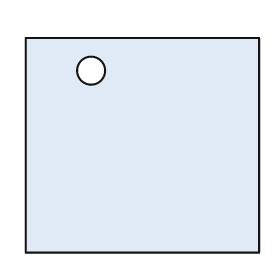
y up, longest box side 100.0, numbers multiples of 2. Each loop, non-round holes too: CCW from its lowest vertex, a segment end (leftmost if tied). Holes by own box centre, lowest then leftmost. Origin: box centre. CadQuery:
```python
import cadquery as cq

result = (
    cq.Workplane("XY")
    .moveTo(-50.0, -46.0)
    .lineTo(50.0, -46.0)
    .lineTo(50.0, 46.0)
    .lineTo(-50.0, 46.0)
    .close()
    .moveTo(-22.0, 32.0)
    .circle(6.0)
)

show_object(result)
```